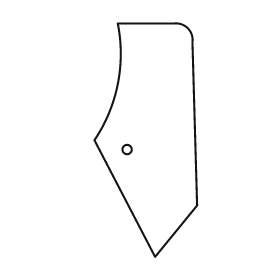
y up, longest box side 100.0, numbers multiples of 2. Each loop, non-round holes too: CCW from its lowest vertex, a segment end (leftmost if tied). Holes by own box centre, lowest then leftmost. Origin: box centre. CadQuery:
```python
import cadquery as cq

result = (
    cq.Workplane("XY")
    .moveTo(4.0, -50.0)
    .lineTo(22.0, -28.0)
    .lineTo(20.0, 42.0)
    .threePointArc((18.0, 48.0), (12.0, 50.0))
    .lineTo(-12.0, 50.0)
    .threePointArc((-12.0, 24.0), (-22.0, 0.0))
    .close()
    .moveTo(-8.0, -4.0)
    .circle(2.0)
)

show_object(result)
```